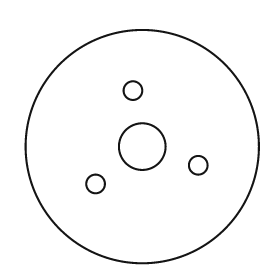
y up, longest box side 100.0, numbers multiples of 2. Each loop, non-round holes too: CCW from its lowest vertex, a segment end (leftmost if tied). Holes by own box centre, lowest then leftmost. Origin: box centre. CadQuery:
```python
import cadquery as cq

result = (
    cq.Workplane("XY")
    .moveTo(0.0, 0.0)
    .circle(50.0)
    .moveTo(-20.0, -16.0)
    .circle(4.0)
    .moveTo(24.0, -8.0)
    .circle(4.0)
    .moveTo(0.0, 0.0)
    .circle(10.0)
    .moveTo(-4.0, 24.0)
    .circle(4.0)
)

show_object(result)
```